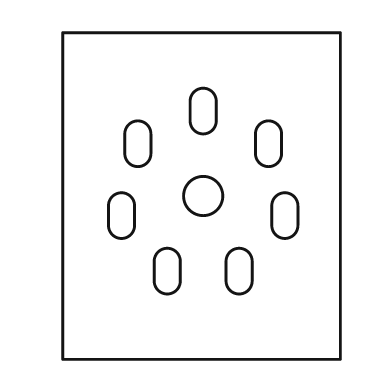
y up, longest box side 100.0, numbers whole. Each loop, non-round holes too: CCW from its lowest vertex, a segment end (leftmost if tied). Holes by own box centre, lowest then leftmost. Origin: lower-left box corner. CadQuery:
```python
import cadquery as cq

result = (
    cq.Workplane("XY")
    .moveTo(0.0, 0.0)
    .lineTo(85.0, 0.0)
    .lineTo(85.0, 100.0)
    .lineTo(0.0, 100.0)
    .close()
    .moveTo(28.0, 24.0)
    .threePointArc((32.0, 20.0), (36.0, 24.0))
    .lineTo(36.0, 30.0)
    .threePointArc((32.0, 34.0), (28.0, 30.0))
    .close()
    .moveTo(50.0, 24.0)
    .threePointArc((54.0, 20.0), (58.0, 24.0))
    .lineTo(58.0, 30.0)
    .threePointArc((54.0, 34.0), (50.0, 30.0))
    .close()
    .moveTo(14.0, 41.0)
    .threePointArc((18.0, 37.0), (22.0, 41.0))
    .lineTo(22.0, 47.0)
    .threePointArc((18.0, 51.0), (14.0, 47.0))
    .close()
    .moveTo(64.0, 41.0)
    .threePointArc((68.0, 37.0), (72.0, 41.0))
    .lineTo(72.0, 47.0)
    .threePointArc((68.0, 51.0), (64.0, 47.0))
    .close()
    .moveTo(43.0, 50.0)
    .circle(6.0)
    .moveTo(19.0, 63.0)
    .threePointArc((23.0, 59.0), (27.0, 63.0))
    .lineTo(27.0, 69.0)
    .threePointArc((23.0, 73.0), (19.0, 69.0))
    .close()
    .moveTo(59.0, 63.0)
    .threePointArc((63.0, 59.0), (67.0, 63.0))
    .lineTo(67.0, 69.0)
    .threePointArc((63.0, 73.0), (59.0, 69.0))
    .close()
    .moveTo(39.0, 73.0)
    .threePointArc((43.0, 69.0), (47.0, 73.0))
    .lineTo(47.0, 79.0)
    .threePointArc((43.0, 83.0), (39.0, 79.0))
    .close()
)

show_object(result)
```